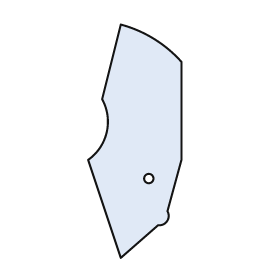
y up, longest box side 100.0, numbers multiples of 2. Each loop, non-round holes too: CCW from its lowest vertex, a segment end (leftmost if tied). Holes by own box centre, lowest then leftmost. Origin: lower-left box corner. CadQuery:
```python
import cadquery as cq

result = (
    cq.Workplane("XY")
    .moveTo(14.0, 0.0)
    .lineTo(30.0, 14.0)
    .threePointArc((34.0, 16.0), (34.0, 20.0))
    .lineTo(40.0, 42.0)
    .lineTo(40.0, 84.0)
    .threePointArc((28.0, 94.0), (14.0, 100.0))
    .lineTo(6.0, 68.0)
    .threePointArc((8.0, 54.0), (0.0, 42.0))
    .close()
    .moveTo(26.0, 34.0)
    .circle(2.0)
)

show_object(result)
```